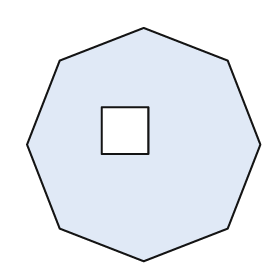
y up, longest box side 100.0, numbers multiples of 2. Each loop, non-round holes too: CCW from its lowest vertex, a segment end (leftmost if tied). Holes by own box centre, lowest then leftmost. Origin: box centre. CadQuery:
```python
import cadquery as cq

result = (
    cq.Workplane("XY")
    .moveTo(0.0, -50.0)
    .lineTo(36.0, -36.0)
    .lineTo(50.0, 0.0)
    .lineTo(36.0, 36.0)
    .lineTo(0.0, 50.0)
    .lineTo(-36.0, 36.0)
    .lineTo(-50.0, 0.0)
    .lineTo(-36.0, -36.0)
    .close()
    .moveTo(-18.0, -4.0)
    .lineTo(2.0, -4.0)
    .lineTo(2.0, 16.0)
    .lineTo(-18.0, 16.0)
    .close()
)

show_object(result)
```